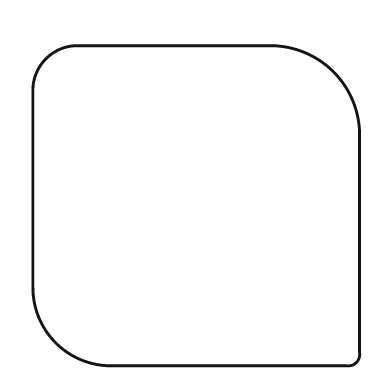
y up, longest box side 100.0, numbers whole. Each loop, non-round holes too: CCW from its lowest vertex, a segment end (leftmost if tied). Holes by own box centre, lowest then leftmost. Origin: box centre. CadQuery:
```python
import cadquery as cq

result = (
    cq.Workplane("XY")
    .moveTo(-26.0, -49.0)
    .lineTo(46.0, -49.0)
    .threePointArc((49.0, -48.0), (50.0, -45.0))
    .lineTo(50.0, 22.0)
    .threePointArc((42.0, 41.0), (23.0, 49.0))
    .lineTo(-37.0, 49.0)
    .threePointArc((-46.0, 45.0), (-50.0, 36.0))
    .lineTo(-50.0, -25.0)
    .threePointArc((-43.0, -42.0), (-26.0, -49.0))
    .close()
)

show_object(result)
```